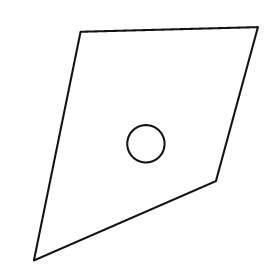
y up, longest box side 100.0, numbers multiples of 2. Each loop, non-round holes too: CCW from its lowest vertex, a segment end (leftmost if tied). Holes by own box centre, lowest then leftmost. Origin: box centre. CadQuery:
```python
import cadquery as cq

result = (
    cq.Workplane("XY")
    .moveTo(-48.0, -50.0)
    .lineTo(30.0, -16.0)
    .lineTo(48.0, 50.0)
    .lineTo(-28.0, 48.0)
    .close()
    .moveTo(0.0, 0.0)
    .circle(8.0)
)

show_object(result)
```